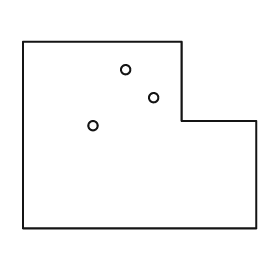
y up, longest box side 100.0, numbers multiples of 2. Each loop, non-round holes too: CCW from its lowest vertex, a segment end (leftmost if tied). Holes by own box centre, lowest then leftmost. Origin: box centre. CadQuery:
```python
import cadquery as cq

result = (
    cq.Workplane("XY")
    .moveTo(-50.0, -40.0)
    .lineTo(50.0, -40.0)
    .lineTo(50.0, 6.0)
    .lineTo(18.0, 6.0)
    .lineTo(18.0, 40.0)
    .lineTo(-50.0, 40.0)
    .close()
    .moveTo(-20.0, 4.0)
    .circle(2.0)
    .moveTo(6.0, 16.0)
    .circle(2.0)
    .moveTo(-6.0, 28.0)
    .circle(2.0)
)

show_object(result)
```